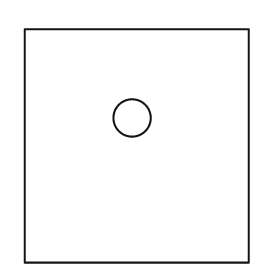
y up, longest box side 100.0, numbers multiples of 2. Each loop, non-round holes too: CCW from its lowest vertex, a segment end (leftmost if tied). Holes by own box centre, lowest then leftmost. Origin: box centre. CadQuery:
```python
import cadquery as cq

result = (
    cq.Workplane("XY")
    .moveTo(-48.0, -50.0)
    .lineTo(48.0, -50.0)
    .lineTo(48.0, 50.0)
    .lineTo(-48.0, 50.0)
    .close()
    .moveTo(-2.0, 12.0)
    .circle(8.0)
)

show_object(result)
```